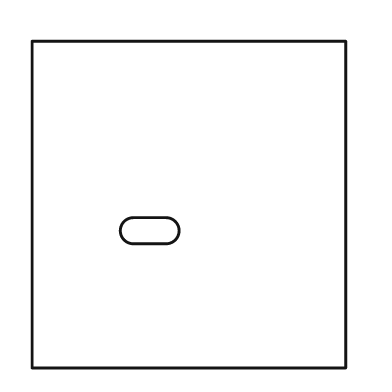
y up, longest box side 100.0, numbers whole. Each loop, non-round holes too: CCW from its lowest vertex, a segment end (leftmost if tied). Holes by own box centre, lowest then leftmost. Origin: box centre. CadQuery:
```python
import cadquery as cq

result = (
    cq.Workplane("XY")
    .moveTo(-48.0, -50.0)
    .lineTo(48.0, -50.0)
    .lineTo(48.0, 50.0)
    .lineTo(-48.0, 50.0)
    .close()
    .moveTo(-17.0, -12.0)
    .lineTo(-7.0, -12.0)
    .threePointArc((-3.0, -8.0), (-7.0, -4.0))
    .lineTo(-17.0, -4.0)
    .threePointArc((-21.0, -8.0), (-17.0, -12.0))
    .close()
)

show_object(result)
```